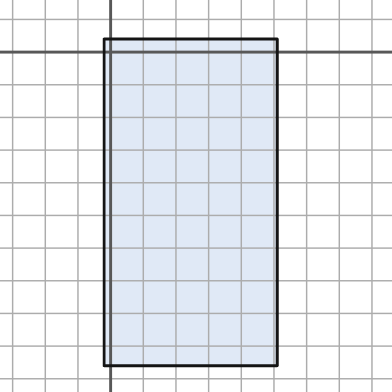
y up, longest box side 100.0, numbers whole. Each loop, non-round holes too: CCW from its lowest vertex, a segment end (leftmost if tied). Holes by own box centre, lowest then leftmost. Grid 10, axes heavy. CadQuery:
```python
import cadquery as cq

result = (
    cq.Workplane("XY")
    .moveTo(-2.0, -96.0)
    .lineTo(51.0, -96.0)
    .lineTo(51.0, 4.0)
    .lineTo(-2.0, 4.0)
    .close()
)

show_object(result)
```